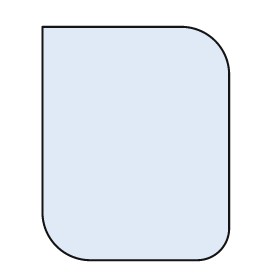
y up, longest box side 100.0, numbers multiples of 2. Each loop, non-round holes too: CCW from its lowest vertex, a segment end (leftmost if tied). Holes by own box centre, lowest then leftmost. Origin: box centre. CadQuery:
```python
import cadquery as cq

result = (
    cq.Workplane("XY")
    .moveTo(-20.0, -50.0)
    .lineTo(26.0, -50.0)
    .threePointArc((36.0, -46.0), (40.0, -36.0))
    .lineTo(40.0, 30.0)
    .threePointArc((34.0, 44.0), (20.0, 50.0))
    .lineTo(-40.0, 50.0)
    .lineTo(-40.0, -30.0)
    .threePointArc((-34.0, -44.0), (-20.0, -50.0))
    .close()
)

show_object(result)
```